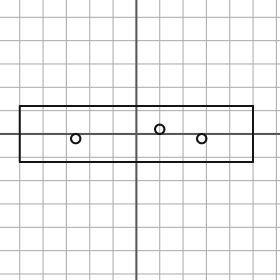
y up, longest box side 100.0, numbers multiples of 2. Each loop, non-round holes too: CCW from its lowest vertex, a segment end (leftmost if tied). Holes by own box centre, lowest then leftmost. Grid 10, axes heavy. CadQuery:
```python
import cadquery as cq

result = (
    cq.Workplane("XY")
    .moveTo(-50.0, -12.0)
    .lineTo(50.0, -12.0)
    .lineTo(50.0, 12.0)
    .lineTo(-50.0, 12.0)
    .close()
    .moveTo(-26.0, -2.0)
    .circle(2.0)
    .moveTo(28.0, -2.0)
    .circle(2.0)
    .moveTo(10.0, 2.0)
    .circle(2.0)
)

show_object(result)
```